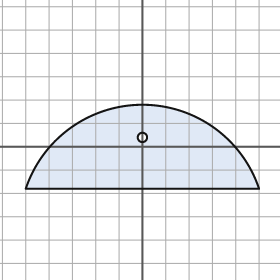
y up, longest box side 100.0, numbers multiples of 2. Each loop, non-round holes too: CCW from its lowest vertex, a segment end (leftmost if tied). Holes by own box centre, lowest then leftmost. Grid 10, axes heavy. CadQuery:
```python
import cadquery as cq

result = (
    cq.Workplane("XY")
    .moveTo(-50.0, -18.0)
    .lineTo(50.0, -18.0)
    .threePointArc((0.0, 18.0), (-50.0, -18.0))
    .close()
    .moveTo(0.0, 4.0)
    .circle(2.0)
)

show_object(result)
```